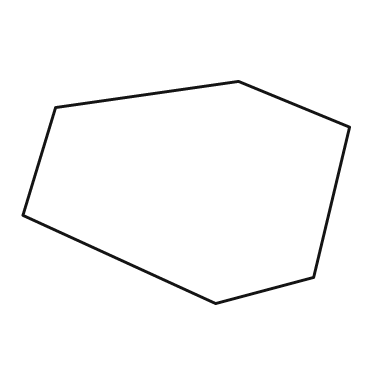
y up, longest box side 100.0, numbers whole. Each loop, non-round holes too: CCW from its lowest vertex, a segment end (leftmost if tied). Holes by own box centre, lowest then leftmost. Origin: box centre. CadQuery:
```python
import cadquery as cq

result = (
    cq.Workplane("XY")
    .moveTo(9.0, -34.0)
    .lineTo(39.0, -26.0)
    .lineTo(50.0, 20.0)
    .lineTo(16.0, 34.0)
    .lineTo(-40.0, 26.0)
    .lineTo(-50.0, -7.0)
    .close()
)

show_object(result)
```